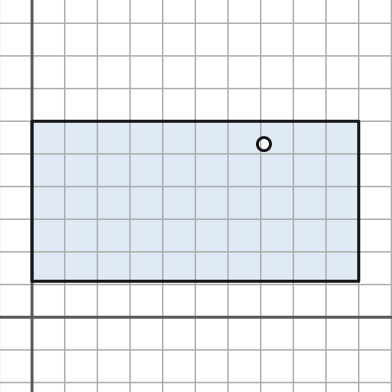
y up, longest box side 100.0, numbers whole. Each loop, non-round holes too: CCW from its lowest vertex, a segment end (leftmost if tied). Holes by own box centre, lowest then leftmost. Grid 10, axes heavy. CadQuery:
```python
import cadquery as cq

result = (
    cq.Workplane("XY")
    .moveTo(0.0, 11.0)
    .lineTo(100.0, 11.0)
    .lineTo(100.0, 60.0)
    .lineTo(0.0, 60.0)
    .close()
    .moveTo(71.0, 53.0)
    .circle(2.0)
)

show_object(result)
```